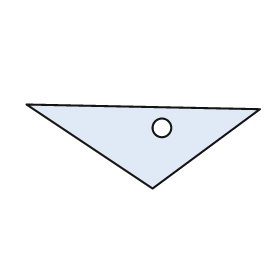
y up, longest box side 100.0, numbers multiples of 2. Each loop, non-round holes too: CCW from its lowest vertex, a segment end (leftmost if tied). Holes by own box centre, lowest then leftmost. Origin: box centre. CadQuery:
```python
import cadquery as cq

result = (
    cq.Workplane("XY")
    .moveTo(4.0, -18.0)
    .lineTo(50.0, 16.0)
    .lineTo(-50.0, 18.0)
    .close()
    .moveTo(8.0, 8.0)
    .circle(4.0)
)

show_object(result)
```